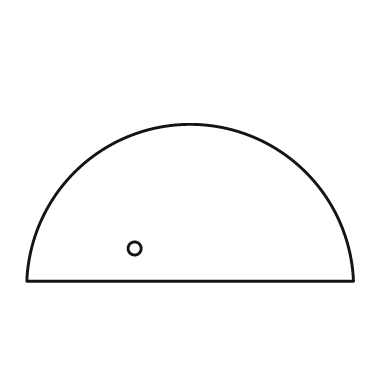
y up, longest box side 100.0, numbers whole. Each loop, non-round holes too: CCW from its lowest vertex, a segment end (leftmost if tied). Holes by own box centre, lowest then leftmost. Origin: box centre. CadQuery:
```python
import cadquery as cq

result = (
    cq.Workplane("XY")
    .moveTo(-50.0, -24.0)
    .lineTo(50.0, -24.0)
    .threePointArc((0.0, 24.0), (-50.0, -24.0))
    .close()
    .moveTo(-17.0, -14.0)
    .circle(2.0)
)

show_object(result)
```